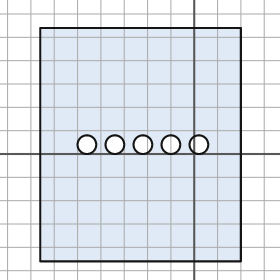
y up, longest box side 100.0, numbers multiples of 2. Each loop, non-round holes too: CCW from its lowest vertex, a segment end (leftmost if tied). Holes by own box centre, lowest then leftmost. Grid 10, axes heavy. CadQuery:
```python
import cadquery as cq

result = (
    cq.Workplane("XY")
    .moveTo(-66.0, -46.0)
    .lineTo(20.0, -46.0)
    .lineTo(20.0, 54.0)
    .lineTo(-66.0, 54.0)
    .close()
    .moveTo(-46.0, 4.0)
    .circle(4.0)
    .moveTo(-34.0, 4.0)
    .circle(4.0)
    .moveTo(-22.0, 4.0)
    .circle(4.0)
    .moveTo(-10.0, 4.0)
    .circle(4.0)
    .moveTo(2.0, 4.0)
    .circle(4.0)
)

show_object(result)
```